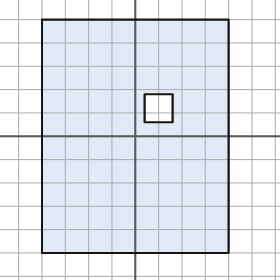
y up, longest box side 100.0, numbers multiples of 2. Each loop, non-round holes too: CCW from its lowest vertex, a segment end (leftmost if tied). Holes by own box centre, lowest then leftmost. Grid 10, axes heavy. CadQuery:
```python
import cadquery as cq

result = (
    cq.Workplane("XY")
    .moveTo(-40.0, -50.0)
    .lineTo(40.0, -50.0)
    .lineTo(40.0, 50.0)
    .lineTo(-40.0, 50.0)
    .close()
    .moveTo(4.0, 6.0)
    .lineTo(16.0, 6.0)
    .lineTo(16.0, 18.0)
    .lineTo(4.0, 18.0)
    .close()
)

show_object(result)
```